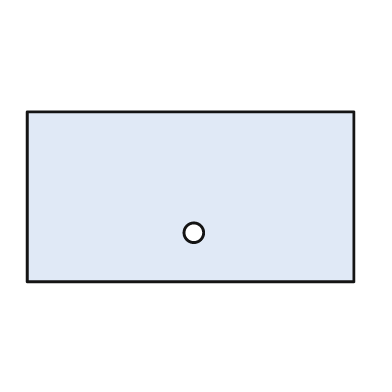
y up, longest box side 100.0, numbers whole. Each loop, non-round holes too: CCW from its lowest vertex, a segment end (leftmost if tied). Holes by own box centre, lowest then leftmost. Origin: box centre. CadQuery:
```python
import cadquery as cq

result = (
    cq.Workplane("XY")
    .moveTo(-50.0, -26.0)
    .lineTo(50.0, -26.0)
    .lineTo(50.0, 26.0)
    .lineTo(-50.0, 26.0)
    .close()
    .moveTo(1.0, -11.0)
    .circle(3.0)
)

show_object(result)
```